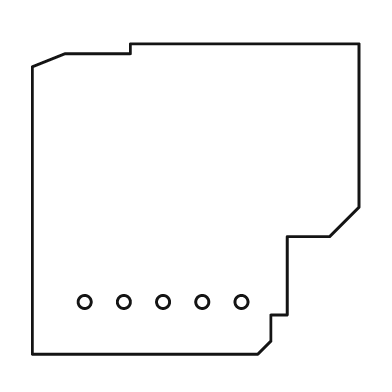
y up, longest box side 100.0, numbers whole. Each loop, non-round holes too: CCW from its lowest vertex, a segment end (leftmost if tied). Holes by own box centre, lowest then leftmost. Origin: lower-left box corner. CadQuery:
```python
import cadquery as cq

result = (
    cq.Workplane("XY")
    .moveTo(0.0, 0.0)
    .lineTo(69.0, 0.0)
    .lineTo(73.0, 4.0)
    .lineTo(73.0, 12.0)
    .lineTo(78.0, 12.0)
    .lineTo(78.0, 36.0)
    .lineTo(91.0, 36.0)
    .lineTo(100.0, 45.0)
    .lineTo(100.0, 95.0)
    .lineTo(30.0, 95.0)
    .lineTo(30.0, 92.0)
    .lineTo(10.0, 92.0)
    .lineTo(0.0, 88.0)
    .close()
    .moveTo(16.0, 16.0)
    .circle(2.0)
    .moveTo(28.0, 16.0)
    .circle(2.0)
    .moveTo(40.0, 16.0)
    .circle(2.0)
    .moveTo(52.0, 16.0)
    .circle(2.0)
    .moveTo(64.0, 16.0)
    .circle(2.0)
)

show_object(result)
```